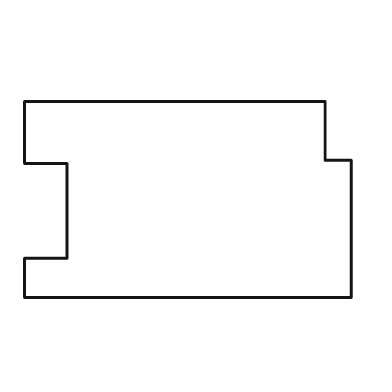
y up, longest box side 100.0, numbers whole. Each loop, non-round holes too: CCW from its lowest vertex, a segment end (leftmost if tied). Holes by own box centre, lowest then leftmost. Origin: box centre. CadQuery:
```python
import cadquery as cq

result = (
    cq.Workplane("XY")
    .moveTo(-50.0, -30.0)
    .lineTo(50.0, -30.0)
    .lineTo(50.0, 12.0)
    .lineTo(42.0, 12.0)
    .lineTo(42.0, 30.0)
    .lineTo(-50.0, 30.0)
    .lineTo(-50.0, 11.0)
    .lineTo(-37.0, 11.0)
    .lineTo(-37.0, -18.0)
    .lineTo(-50.0, -18.0)
    .close()
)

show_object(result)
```